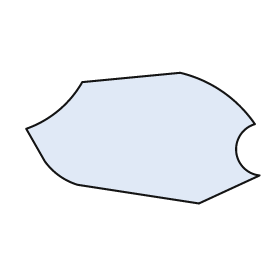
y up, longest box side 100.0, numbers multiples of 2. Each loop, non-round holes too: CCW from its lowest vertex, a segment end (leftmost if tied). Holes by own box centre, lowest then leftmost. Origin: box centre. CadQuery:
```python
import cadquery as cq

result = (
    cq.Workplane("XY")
    .moveTo(24.0, -28.0)
    .lineTo(50.0, -16.0)
    .threePointArc((40.0, -6.0), (48.0, 6.0))
    .threePointArc((34.0, 20.0), (16.0, 28.0))
    .lineTo(-26.0, 24.0)
    .threePointArc((-36.0, 12.0), (-50.0, 4.0))
    .lineTo(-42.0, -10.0)
    .threePointArc((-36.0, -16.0), (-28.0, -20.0))
    .close()
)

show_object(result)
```